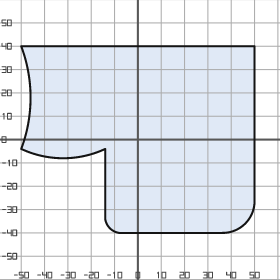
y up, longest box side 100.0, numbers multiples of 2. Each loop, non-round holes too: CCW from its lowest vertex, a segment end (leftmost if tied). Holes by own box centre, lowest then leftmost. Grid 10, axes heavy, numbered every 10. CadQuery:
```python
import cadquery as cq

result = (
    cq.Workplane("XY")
    .moveTo(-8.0, -40.0)
    .lineTo(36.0, -40.0)
    .threePointArc((46.0, -36.0), (50.0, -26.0))
    .lineTo(50.0, 40.0)
    .lineTo(-50.0, 40.0)
    .threePointArc((-46.0, 18.0), (-50.0, -4.0))
    .threePointArc((-32.0, -8.0), (-14.0, -4.0))
    .lineTo(-14.0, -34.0)
    .threePointArc((-12.0, -38.0), (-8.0, -40.0))
    .close()
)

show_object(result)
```